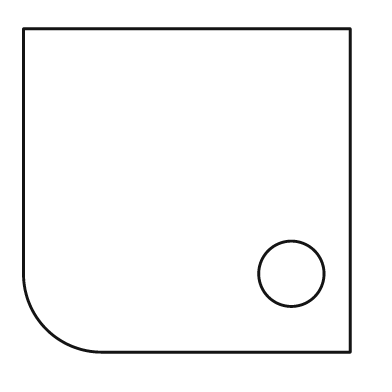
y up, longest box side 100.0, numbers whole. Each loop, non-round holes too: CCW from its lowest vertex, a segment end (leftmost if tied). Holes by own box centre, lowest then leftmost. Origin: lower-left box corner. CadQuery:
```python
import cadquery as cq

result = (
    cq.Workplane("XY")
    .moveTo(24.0, 0.0)
    .lineTo(100.0, 0.0)
    .lineTo(100.0, 99.0)
    .lineTo(0.0, 99.0)
    .lineTo(0.0, 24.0)
    .threePointArc((7.0, 7.0), (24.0, 0.0))
    .close()
    .moveTo(82.0, 24.0)
    .circle(10.0)
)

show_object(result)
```